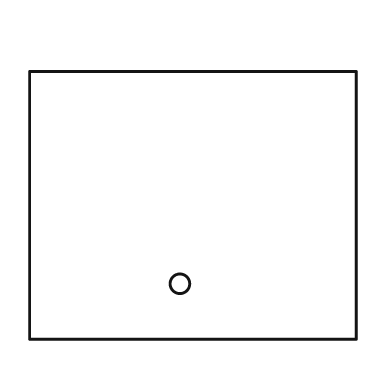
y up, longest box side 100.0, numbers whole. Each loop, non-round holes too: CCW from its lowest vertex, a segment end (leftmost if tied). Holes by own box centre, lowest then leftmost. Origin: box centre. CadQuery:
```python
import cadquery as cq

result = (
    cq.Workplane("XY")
    .moveTo(-50.0, -41.0)
    .lineTo(50.0, -41.0)
    .lineTo(50.0, 41.0)
    .lineTo(-50.0, 41.0)
    .close()
    .moveTo(-4.0, -24.0)
    .circle(3.0)
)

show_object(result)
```